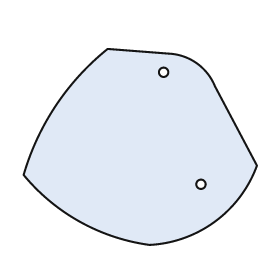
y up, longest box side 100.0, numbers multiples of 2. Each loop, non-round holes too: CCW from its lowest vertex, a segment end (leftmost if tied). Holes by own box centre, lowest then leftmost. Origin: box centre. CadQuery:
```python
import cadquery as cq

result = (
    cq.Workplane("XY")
    .moveTo(4.0, -42.0)
    .threePointArc((32.0, -32.0), (50.0, -8.0))
    .lineTo(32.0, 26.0)
    .threePointArc((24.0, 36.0), (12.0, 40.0))
    .lineTo(-14.0, 42.0)
    .threePointArc((-36.0, 18.0), (-50.0, -12.0))
    .threePointArc((-26.0, -32.0), (4.0, -42.0))
    .close()
    .moveTo(26.0, -16.0)
    .circle(2.0)
    .moveTo(10.0, 32.0)
    .circle(2.0)
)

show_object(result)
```